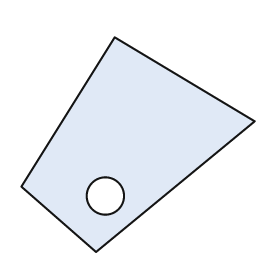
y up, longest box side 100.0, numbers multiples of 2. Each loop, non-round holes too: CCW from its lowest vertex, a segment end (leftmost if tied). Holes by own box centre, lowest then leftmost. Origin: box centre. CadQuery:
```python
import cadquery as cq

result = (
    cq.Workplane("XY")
    .moveTo(-18.0, -46.0)
    .lineTo(50.0, 10.0)
    .lineTo(-10.0, 46.0)
    .lineTo(-50.0, -18.0)
    .close()
    .moveTo(-14.0, -22.0)
    .circle(8.0)
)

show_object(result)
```